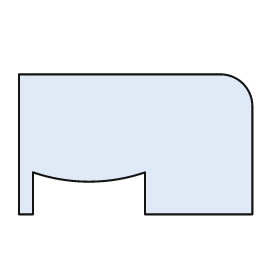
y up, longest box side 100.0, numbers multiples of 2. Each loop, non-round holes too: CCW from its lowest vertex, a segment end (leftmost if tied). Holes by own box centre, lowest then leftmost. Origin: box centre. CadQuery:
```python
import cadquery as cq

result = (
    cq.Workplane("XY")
    .moveTo(-50.0, -30.0)
    .lineTo(-44.0, -30.0)
    .lineTo(-44.0, -12.0)
    .threePointArc((-20.0, -16.0), (4.0, -12.0))
    .lineTo(4.0, -30.0)
    .lineTo(50.0, -30.0)
    .lineTo(50.0, 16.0)
    .threePointArc((46.0, 26.0), (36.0, 30.0))
    .lineTo(-50.0, 30.0)
    .close()
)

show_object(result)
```